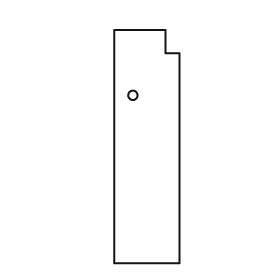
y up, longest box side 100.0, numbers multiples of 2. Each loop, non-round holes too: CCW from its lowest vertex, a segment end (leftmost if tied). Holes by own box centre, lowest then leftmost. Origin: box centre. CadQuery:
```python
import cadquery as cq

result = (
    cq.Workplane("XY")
    .moveTo(-14.0, -50.0)
    .lineTo(14.0, -50.0)
    .lineTo(14.0, 40.0)
    .lineTo(8.0, 40.0)
    .lineTo(8.0, 50.0)
    .lineTo(-14.0, 50.0)
    .close()
    .moveTo(-6.0, 22.0)
    .circle(2.0)
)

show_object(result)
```